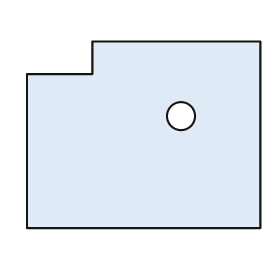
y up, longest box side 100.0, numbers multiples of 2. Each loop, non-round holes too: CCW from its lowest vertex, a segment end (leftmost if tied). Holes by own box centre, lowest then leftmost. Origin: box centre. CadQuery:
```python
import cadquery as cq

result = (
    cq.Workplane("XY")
    .moveTo(-50.0, -40.0)
    .lineTo(50.0, -40.0)
    .lineTo(50.0, 40.0)
    .lineTo(-22.0, 40.0)
    .lineTo(-22.0, 26.0)
    .lineTo(-50.0, 26.0)
    .close()
    .moveTo(16.0, 8.0)
    .circle(6.0)
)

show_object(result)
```